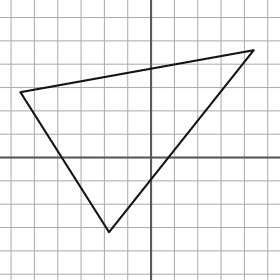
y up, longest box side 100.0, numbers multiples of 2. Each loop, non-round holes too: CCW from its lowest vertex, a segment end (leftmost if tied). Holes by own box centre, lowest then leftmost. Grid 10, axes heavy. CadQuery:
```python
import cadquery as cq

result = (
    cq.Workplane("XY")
    .moveTo(-18.0, -32.0)
    .lineTo(44.0, 46.0)
    .lineTo(-56.0, 28.0)
    .close()
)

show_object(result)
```